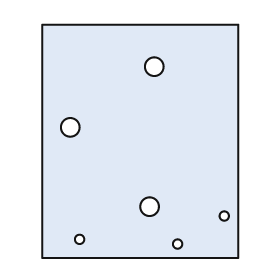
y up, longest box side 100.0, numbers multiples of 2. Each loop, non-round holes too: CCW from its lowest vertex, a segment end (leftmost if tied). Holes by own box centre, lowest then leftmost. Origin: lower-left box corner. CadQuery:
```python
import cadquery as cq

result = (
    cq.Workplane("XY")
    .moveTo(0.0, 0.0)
    .lineTo(84.0, 0.0)
    .lineTo(84.0, 100.0)
    .lineTo(0.0, 100.0)
    .close()
    .moveTo(58.0, 6.0)
    .circle(2.0)
    .moveTo(16.0, 8.0)
    .circle(2.0)
    .moveTo(78.0, 18.0)
    .circle(2.0)
    .moveTo(46.0, 22.0)
    .circle(4.0)
    .moveTo(12.0, 56.0)
    .circle(4.0)
    .moveTo(48.0, 82.0)
    .circle(4.0)
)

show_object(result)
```